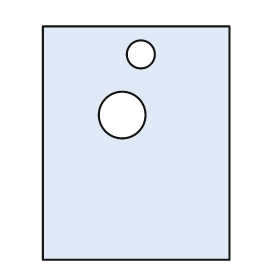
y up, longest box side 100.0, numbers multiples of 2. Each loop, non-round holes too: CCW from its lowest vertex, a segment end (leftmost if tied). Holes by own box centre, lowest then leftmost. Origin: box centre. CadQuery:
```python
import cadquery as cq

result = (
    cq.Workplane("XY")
    .moveTo(-40.0, -50.0)
    .lineTo(40.0, -50.0)
    .lineTo(40.0, 50.0)
    .lineTo(-40.0, 50.0)
    .close()
    .moveTo(-6.0, 12.0)
    .circle(10.0)
    .moveTo(2.0, 38.0)
    .circle(6.0)
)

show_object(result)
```